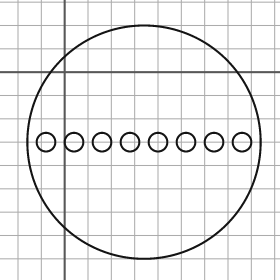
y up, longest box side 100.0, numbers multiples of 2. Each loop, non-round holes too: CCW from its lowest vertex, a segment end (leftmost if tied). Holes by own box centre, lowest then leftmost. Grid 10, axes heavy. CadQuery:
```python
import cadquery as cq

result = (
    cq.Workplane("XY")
    .moveTo(34.0, -30.0)
    .circle(50.0)
    .moveTo(-8.0, -30.0)
    .circle(4.0)
    .moveTo(4.0, -30.0)
    .circle(4.0)
    .moveTo(16.0, -30.0)
    .circle(4.0)
    .moveTo(28.0, -30.0)
    .circle(4.0)
    .moveTo(40.0, -30.0)
    .circle(4.0)
    .moveTo(52.0, -30.0)
    .circle(4.0)
    .moveTo(64.0, -30.0)
    .circle(4.0)
    .moveTo(76.0, -30.0)
    .circle(4.0)
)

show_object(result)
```